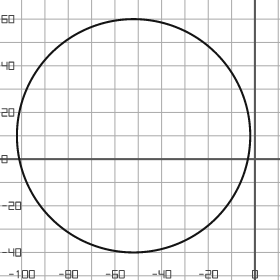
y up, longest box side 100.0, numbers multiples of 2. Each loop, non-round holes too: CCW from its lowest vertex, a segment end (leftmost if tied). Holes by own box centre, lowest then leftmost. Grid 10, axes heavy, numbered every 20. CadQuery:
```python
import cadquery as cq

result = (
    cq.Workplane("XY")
    .moveTo(-52.0, 10.0)
    .circle(50.0)
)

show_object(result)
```